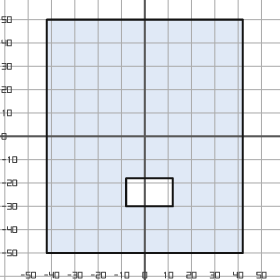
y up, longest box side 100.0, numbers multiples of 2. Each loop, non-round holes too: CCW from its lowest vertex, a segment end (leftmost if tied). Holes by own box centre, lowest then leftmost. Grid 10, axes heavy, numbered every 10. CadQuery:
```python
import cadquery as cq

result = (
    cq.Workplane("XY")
    .moveTo(-42.0, -50.0)
    .lineTo(42.0, -50.0)
    .lineTo(42.0, 50.0)
    .lineTo(-42.0, 50.0)
    .close()
    .moveTo(-8.0, -30.0)
    .lineTo(12.0, -30.0)
    .lineTo(12.0, -18.0)
    .lineTo(-8.0, -18.0)
    .close()
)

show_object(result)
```